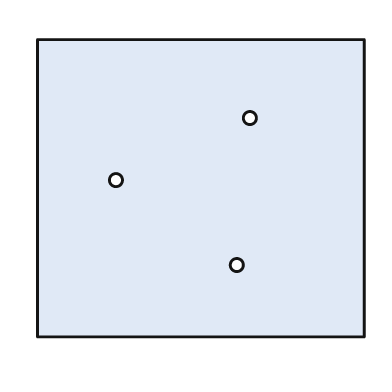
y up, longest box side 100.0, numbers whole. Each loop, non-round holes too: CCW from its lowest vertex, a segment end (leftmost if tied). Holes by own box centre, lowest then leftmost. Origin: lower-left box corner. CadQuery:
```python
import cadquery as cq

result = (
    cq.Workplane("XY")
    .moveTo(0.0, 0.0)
    .lineTo(100.0, 0.0)
    .lineTo(100.0, 91.0)
    .lineTo(0.0, 91.0)
    .close()
    .moveTo(61.0, 22.0)
    .circle(2.0)
    .moveTo(24.0, 48.0)
    .circle(2.0)
    .moveTo(65.0, 67.0)
    .circle(2.0)
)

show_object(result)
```